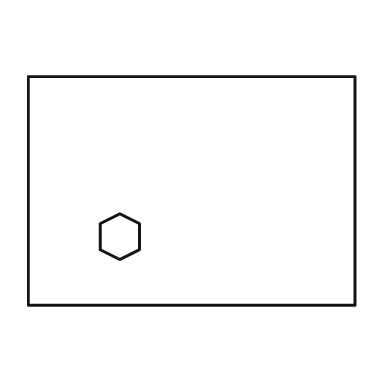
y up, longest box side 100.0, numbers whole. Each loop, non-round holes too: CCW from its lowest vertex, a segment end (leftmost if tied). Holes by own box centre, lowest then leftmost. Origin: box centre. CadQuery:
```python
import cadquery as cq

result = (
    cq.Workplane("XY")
    .moveTo(-50.0, -35.0)
    .lineTo(50.0, -35.0)
    .lineTo(50.0, 35.0)
    .lineTo(-50.0, 35.0)
    .close()
    .moveTo(-22.0, -21.0)
    .lineTo(-16.0, -18.0)
    .lineTo(-16.0, -10.0)
    .lineTo(-22.0, -7.0)
    .lineTo(-28.0, -10.0)
    .lineTo(-28.0, -18.0)
    .close()
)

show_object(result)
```